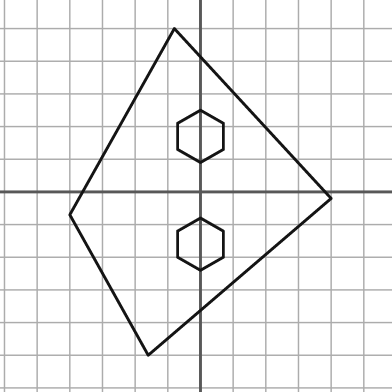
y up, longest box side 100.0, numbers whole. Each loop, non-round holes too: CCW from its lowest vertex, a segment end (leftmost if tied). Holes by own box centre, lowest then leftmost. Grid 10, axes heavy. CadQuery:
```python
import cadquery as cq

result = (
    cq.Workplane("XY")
    .moveTo(-16.0, -50.0)
    .lineTo(40.0, -2.0)
    .lineTo(-8.0, 50.0)
    .lineTo(-40.0, -7.0)
    .close()
    .moveTo(0.0, -24.0)
    .lineTo(7.0, -20.0)
    .lineTo(7.0, -12.0)
    .lineTo(0.0, -8.0)
    .lineTo(-7.0, -12.0)
    .lineTo(-7.0, -20.0)
    .close()
    .moveTo(0.0, 9.0)
    .lineTo(7.0, 13.0)
    .lineTo(7.0, 21.0)
    .lineTo(0.0, 25.0)
    .lineTo(-7.0, 21.0)
    .lineTo(-7.0, 13.0)
    .close()
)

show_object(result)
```